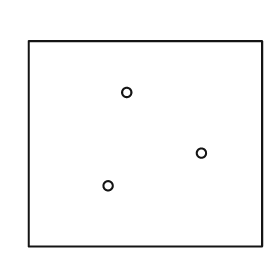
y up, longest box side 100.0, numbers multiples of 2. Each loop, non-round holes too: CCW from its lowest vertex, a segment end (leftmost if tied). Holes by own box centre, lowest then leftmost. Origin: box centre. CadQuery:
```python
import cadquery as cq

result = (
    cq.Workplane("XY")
    .moveTo(-50.0, -44.0)
    .lineTo(50.0, -44.0)
    .lineTo(50.0, 44.0)
    .lineTo(-50.0, 44.0)
    .close()
    .moveTo(-16.0, -18.0)
    .circle(2.0)
    .moveTo(24.0, -4.0)
    .circle(2.0)
    .moveTo(-8.0, 22.0)
    .circle(2.0)
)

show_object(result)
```